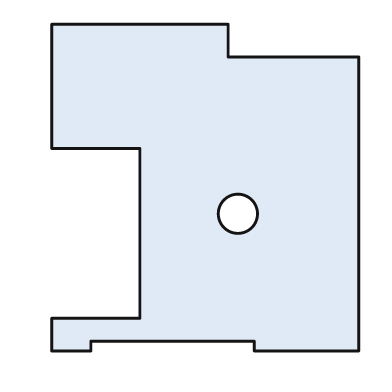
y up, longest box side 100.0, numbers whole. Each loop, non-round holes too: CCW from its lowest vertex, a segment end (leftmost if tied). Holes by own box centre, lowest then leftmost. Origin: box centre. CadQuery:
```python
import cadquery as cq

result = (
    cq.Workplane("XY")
    .moveTo(-47.0, -50.0)
    .lineTo(-35.0, -50.0)
    .lineTo(-35.0, -47.0)
    .lineTo(15.0, -47.0)
    .lineTo(15.0, -50.0)
    .lineTo(47.0, -50.0)
    .lineTo(47.0, 40.0)
    .lineTo(7.0, 40.0)
    .lineTo(7.0, 50.0)
    .lineTo(-47.0, 50.0)
    .lineTo(-47.0, 12.0)
    .lineTo(-20.0, 12.0)
    .lineTo(-20.0, -40.0)
    .lineTo(-47.0, -40.0)
    .close()
    .moveTo(10.0, -8.0)
    .circle(6.0)
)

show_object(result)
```